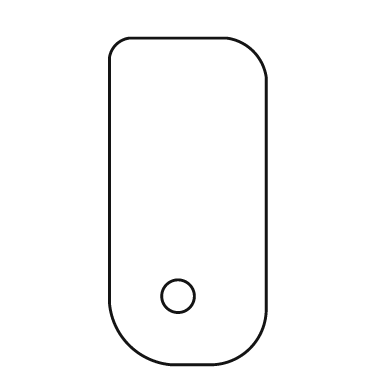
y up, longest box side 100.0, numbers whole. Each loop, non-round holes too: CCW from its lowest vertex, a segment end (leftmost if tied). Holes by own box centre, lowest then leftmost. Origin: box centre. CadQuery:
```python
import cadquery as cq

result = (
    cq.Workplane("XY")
    .moveTo(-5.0, -50.0)
    .lineTo(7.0, -50.0)
    .threePointArc((19.0, -45.0), (24.0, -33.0))
    .lineTo(24.0, 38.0)
    .threePointArc((20.0, 46.0), (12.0, 50.0))
    .lineTo(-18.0, 50.0)
    .threePointArc((-22.0, 48.0), (-24.0, 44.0))
    .lineTo(-24.0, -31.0)
    .threePointArc((-18.0, -44.0), (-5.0, -50.0))
    .close()
    .moveTo(-3.0, -29.0)
    .circle(5.0)
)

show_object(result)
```